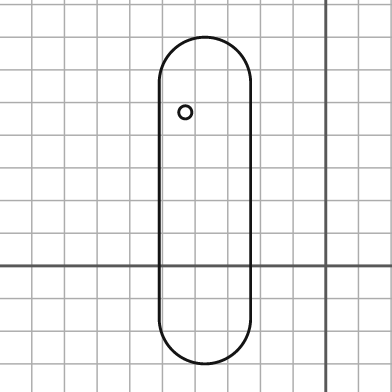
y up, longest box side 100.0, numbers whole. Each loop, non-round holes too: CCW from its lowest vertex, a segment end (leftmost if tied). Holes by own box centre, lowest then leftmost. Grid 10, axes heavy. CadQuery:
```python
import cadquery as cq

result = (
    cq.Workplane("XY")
    .moveTo(-51.0, -16.0)
    .threePointArc((-37.0, -30.0), (-23.0, -16.0))
    .lineTo(-23.0, 56.0)
    .threePointArc((-37.0, 70.0), (-51.0, 56.0))
    .close()
    .moveTo(-43.0, 47.0)
    .circle(2.0)
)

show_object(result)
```